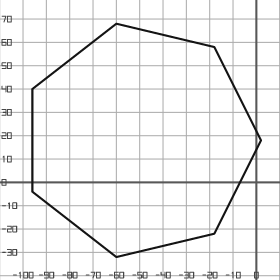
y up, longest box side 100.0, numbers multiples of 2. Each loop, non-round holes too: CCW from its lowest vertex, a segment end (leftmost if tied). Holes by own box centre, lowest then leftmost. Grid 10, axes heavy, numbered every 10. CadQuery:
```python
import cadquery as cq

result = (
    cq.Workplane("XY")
    .moveTo(-60.0, -32.0)
    .lineTo(-18.0, -22.0)
    .lineTo(2.0, 18.0)
    .lineTo(-18.0, 58.0)
    .lineTo(-60.0, 68.0)
    .lineTo(-96.0, 40.0)
    .lineTo(-96.0, -4.0)
    .close()
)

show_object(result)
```